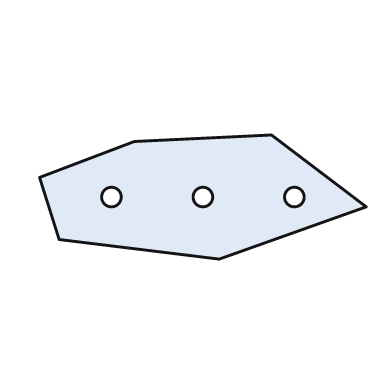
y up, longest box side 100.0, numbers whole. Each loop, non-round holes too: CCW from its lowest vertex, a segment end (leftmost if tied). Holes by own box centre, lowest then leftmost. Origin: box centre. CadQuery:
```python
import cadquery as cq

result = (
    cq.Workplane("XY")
    .moveTo(5.0, -19.0)
    .lineTo(50.0, -3.0)
    .lineTo(21.0, 19.0)
    .lineTo(-21.0, 17.0)
    .lineTo(-50.0, 6.0)
    .lineTo(-44.0, -13.0)
    .close()
    .moveTo(-28.0, 0.0)
    .circle(3.0)
    .moveTo(0.0, 0.0)
    .circle(3.0)
    .moveTo(28.0, 0.0)
    .circle(3.0)
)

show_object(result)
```